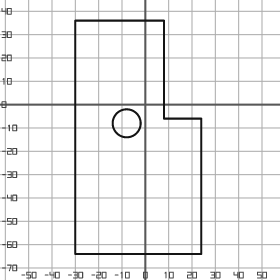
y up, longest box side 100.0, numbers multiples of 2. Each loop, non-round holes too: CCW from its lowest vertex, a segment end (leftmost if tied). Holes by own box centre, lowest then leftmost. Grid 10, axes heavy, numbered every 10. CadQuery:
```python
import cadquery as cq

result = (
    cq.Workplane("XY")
    .moveTo(-30.0, -64.0)
    .lineTo(24.0, -64.0)
    .lineTo(24.0, -6.0)
    .lineTo(8.0, -6.0)
    .lineTo(8.0, 36.0)
    .lineTo(-30.0, 36.0)
    .close()
    .moveTo(-8.0, -8.0)
    .circle(6.0)
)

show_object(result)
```